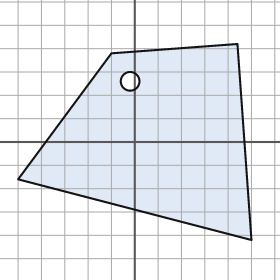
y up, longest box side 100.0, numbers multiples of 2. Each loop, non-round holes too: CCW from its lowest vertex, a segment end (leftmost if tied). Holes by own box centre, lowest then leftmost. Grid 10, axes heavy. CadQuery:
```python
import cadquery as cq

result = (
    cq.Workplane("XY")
    .moveTo(50.0, -42.0)
    .lineTo(44.0, 42.0)
    .lineTo(-10.0, 38.0)
    .lineTo(-50.0, -16.0)
    .close()
    .moveTo(-2.0, 26.0)
    .circle(4.0)
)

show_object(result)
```